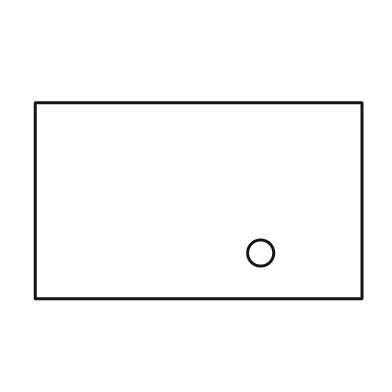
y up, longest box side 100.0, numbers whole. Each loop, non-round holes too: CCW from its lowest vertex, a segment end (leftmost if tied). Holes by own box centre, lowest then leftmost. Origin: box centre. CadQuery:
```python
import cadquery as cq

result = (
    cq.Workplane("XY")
    .moveTo(-50.0, -30.0)
    .lineTo(50.0, -30.0)
    .lineTo(50.0, 30.0)
    .lineTo(-50.0, 30.0)
    .close()
    .moveTo(19.0, -16.0)
    .circle(4.0)
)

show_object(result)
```